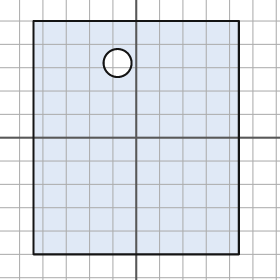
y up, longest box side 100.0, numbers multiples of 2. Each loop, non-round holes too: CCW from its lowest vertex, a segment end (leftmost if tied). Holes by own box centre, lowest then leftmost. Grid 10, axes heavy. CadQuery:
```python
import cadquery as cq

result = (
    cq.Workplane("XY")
    .moveTo(-44.0, -50.0)
    .lineTo(44.0, -50.0)
    .lineTo(44.0, 50.0)
    .lineTo(-44.0, 50.0)
    .close()
    .moveTo(-8.0, 32.0)
    .circle(6.0)
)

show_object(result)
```